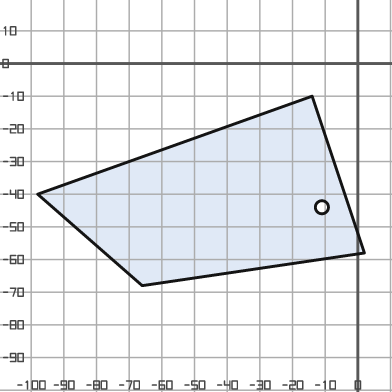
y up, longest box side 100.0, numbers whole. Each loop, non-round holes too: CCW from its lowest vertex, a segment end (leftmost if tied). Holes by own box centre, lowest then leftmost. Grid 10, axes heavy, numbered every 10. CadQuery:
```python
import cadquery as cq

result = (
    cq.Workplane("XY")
    .moveTo(-66.0, -68.0)
    .lineTo(2.0, -58.0)
    .lineTo(-14.0, -10.0)
    .lineTo(-98.0, -40.0)
    .close()
    .moveTo(-11.0, -44.0)
    .circle(2.0)
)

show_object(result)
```